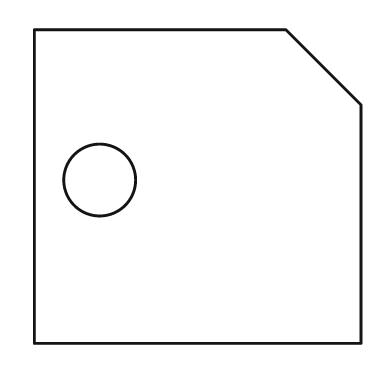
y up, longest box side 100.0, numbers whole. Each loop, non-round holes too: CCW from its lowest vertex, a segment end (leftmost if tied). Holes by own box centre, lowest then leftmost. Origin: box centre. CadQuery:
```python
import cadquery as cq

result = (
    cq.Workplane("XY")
    .moveTo(-50.0, -48.0)
    .lineTo(50.0, -48.0)
    .lineTo(50.0, 25.0)
    .lineTo(27.0, 48.0)
    .lineTo(-50.0, 48.0)
    .close()
    .moveTo(-30.0, 2.0)
    .circle(11.0)
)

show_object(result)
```